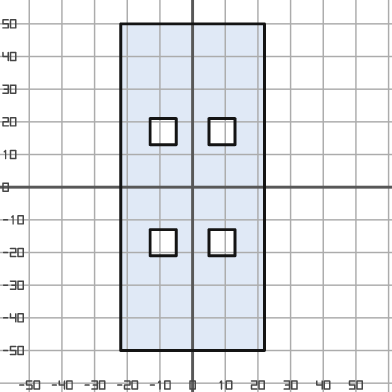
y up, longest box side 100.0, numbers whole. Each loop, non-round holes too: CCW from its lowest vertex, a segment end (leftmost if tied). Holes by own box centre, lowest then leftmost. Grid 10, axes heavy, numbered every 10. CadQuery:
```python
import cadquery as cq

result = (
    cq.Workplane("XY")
    .moveTo(-22.0, -50.0)
    .lineTo(22.0, -50.0)
    .lineTo(22.0, 50.0)
    .lineTo(-22.0, 50.0)
    .close()
    .moveTo(-13.0, -21.0)
    .lineTo(-5.0, -21.0)
    .lineTo(-5.0, -13.0)
    .lineTo(-13.0, -13.0)
    .close()
    .moveTo(5.0, -21.0)
    .lineTo(13.0, -21.0)
    .lineTo(13.0, -13.0)
    .lineTo(5.0, -13.0)
    .close()
    .moveTo(-13.0, 13.0)
    .lineTo(-5.0, 13.0)
    .lineTo(-5.0, 21.0)
    .lineTo(-13.0, 21.0)
    .close()
    .moveTo(5.0, 13.0)
    .lineTo(13.0, 13.0)
    .lineTo(13.0, 21.0)
    .lineTo(5.0, 21.0)
    .close()
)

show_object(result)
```